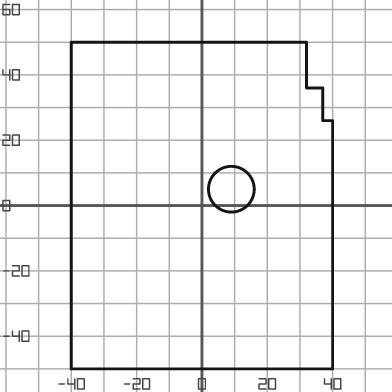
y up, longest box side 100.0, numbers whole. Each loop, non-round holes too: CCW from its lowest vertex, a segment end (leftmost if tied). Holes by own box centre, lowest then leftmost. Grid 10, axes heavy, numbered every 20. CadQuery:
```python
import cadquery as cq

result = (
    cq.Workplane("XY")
    .moveTo(-40.0, -50.0)
    .lineTo(40.0, -50.0)
    .lineTo(40.0, 26.0)
    .lineTo(37.0, 26.0)
    .lineTo(37.0, 36.0)
    .lineTo(32.0, 36.0)
    .lineTo(32.0, 50.0)
    .lineTo(-40.0, 50.0)
    .close()
    .moveTo(9.0, 5.0)
    .circle(7.0)
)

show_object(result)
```